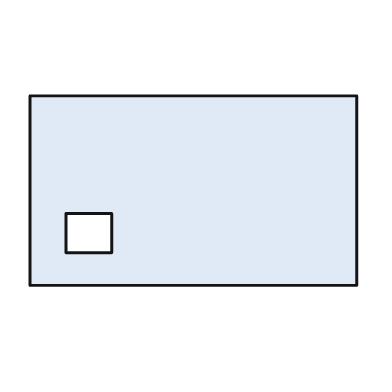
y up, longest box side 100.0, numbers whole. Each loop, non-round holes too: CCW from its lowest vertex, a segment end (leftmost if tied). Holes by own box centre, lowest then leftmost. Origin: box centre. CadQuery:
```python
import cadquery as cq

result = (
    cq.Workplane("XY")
    .moveTo(-50.0, -29.0)
    .lineTo(50.0, -29.0)
    .lineTo(50.0, 29.0)
    .lineTo(-50.0, 29.0)
    .close()
    .moveTo(-39.0, -19.0)
    .lineTo(-25.0, -19.0)
    .lineTo(-25.0, -7.0)
    .lineTo(-39.0, -7.0)
    .close()
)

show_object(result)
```